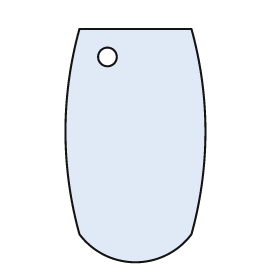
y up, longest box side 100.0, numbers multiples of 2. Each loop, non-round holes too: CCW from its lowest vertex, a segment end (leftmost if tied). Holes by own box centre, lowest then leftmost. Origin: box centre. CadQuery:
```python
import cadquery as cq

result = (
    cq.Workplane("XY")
    .moveTo(-24.0, -38.0)
    .threePointArc((0.0, -50.0), (24.0, -38.0))
    .threePointArc((30.0, 6.0), (24.0, 50.0))
    .lineTo(-24.0, 50.0)
    .threePointArc((-30.0, 6.0), (-24.0, -38.0))
    .close()
    .moveTo(-12.0, 38.0)
    .circle(4.0)
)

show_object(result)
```